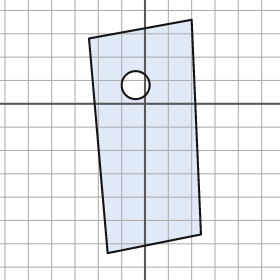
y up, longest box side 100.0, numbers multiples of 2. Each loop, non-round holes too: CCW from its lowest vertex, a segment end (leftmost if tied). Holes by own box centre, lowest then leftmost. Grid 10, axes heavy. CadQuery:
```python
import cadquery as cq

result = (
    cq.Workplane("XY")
    .moveTo(-16.0, -64.0)
    .lineTo(24.0, -56.0)
    .lineTo(20.0, 36.0)
    .lineTo(-24.0, 28.0)
    .close()
    .moveTo(-4.0, 8.0)
    .circle(6.0)
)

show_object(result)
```